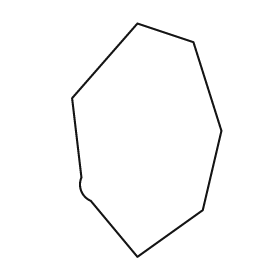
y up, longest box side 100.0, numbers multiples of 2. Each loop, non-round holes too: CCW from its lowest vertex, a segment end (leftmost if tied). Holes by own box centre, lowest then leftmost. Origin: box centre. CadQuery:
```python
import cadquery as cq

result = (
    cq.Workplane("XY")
    .moveTo(-4.0, -50.0)
    .lineTo(24.0, -30.0)
    .lineTo(32.0, 4.0)
    .lineTo(20.0, 42.0)
    .lineTo(-4.0, 50.0)
    .lineTo(-32.0, 18.0)
    .lineTo(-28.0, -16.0)
    .threePointArc((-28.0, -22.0), (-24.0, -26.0))
    .close()
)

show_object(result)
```